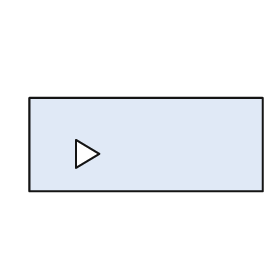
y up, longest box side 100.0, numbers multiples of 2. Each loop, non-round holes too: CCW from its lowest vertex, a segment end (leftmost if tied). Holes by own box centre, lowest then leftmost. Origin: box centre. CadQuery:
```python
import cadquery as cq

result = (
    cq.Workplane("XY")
    .moveTo(-50.0, -20.0)
    .lineTo(50.0, -20.0)
    .lineTo(50.0, 20.0)
    .lineTo(-50.0, 20.0)
    .close()
    .moveTo(-30.0, -10.0)
    .lineTo(-20.0, -4.0)
    .lineTo(-30.0, 2.0)
    .close()
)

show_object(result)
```